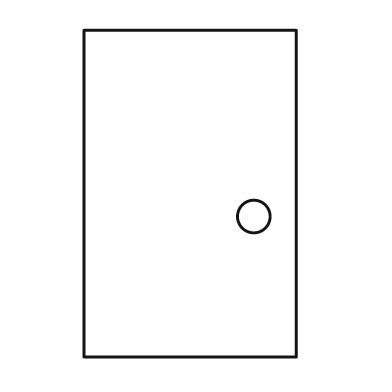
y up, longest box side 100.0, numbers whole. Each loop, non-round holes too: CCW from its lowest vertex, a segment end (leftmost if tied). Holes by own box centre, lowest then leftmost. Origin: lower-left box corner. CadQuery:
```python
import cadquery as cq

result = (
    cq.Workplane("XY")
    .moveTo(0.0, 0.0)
    .lineTo(65.0, 0.0)
    .lineTo(65.0, 100.0)
    .lineTo(0.0, 100.0)
    .close()
    .moveTo(52.0, 43.0)
    .circle(5.0)
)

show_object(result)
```